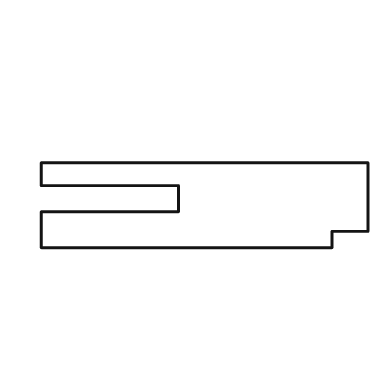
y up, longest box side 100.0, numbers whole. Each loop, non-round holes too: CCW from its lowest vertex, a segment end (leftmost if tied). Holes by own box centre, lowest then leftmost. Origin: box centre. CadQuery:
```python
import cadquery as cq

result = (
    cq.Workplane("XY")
    .moveTo(-50.0, -13.0)
    .lineTo(39.0, -13.0)
    .lineTo(39.0, -8.0)
    .lineTo(50.0, -8.0)
    .lineTo(50.0, 13.0)
    .lineTo(-50.0, 13.0)
    .lineTo(-50.0, 6.0)
    .lineTo(-8.0, 6.0)
    .lineTo(-8.0, -2.0)
    .lineTo(-50.0, -2.0)
    .close()
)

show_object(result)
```